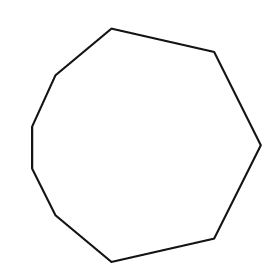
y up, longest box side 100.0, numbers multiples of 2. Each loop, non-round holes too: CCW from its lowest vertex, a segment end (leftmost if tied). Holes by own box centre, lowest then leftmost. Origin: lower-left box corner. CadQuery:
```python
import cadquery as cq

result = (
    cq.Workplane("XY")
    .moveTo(34.0, 0.0)
    .lineTo(78.0, 10.0)
    .lineTo(98.0, 50.0)
    .lineTo(78.0, 90.0)
    .lineTo(34.0, 100.0)
    .lineTo(10.0, 80.0)
    .lineTo(0.0, 58.0)
    .lineTo(0.0, 40.0)
    .lineTo(10.0, 20.0)
    .close()
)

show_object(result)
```